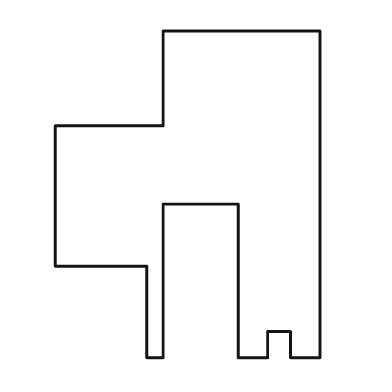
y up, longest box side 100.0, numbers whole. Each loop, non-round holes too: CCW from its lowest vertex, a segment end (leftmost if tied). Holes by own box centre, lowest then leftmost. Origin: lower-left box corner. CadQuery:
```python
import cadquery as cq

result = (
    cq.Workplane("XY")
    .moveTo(28.0, 0.0)
    .lineTo(33.0, 0.0)
    .lineTo(33.0, 47.0)
    .lineTo(56.0, 47.0)
    .lineTo(56.0, 0.0)
    .lineTo(65.0, 0.0)
    .lineTo(65.0, 8.0)
    .lineTo(72.0, 8.0)
    .lineTo(72.0, 0.0)
    .lineTo(81.0, 0.0)
    .lineTo(81.0, 100.0)
    .lineTo(33.0, 100.0)
    .lineTo(33.0, 71.0)
    .lineTo(0.0, 71.0)
    .lineTo(0.0, 28.0)
    .lineTo(28.0, 28.0)
    .close()
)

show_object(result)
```